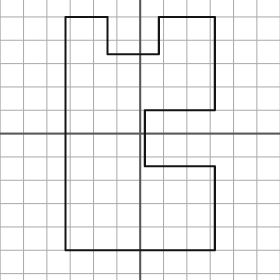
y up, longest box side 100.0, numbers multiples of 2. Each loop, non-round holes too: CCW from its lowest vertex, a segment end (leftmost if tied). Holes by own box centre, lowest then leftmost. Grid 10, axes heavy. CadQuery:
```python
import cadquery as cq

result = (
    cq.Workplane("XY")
    .moveTo(-32.0, -50.0)
    .lineTo(32.0, -50.0)
    .lineTo(32.0, -14.0)
    .lineTo(2.0, -14.0)
    .lineTo(2.0, 10.0)
    .lineTo(32.0, 10.0)
    .lineTo(32.0, 50.0)
    .lineTo(8.0, 50.0)
    .lineTo(8.0, 34.0)
    .lineTo(-14.0, 34.0)
    .lineTo(-14.0, 50.0)
    .lineTo(-32.0, 50.0)
    .close()
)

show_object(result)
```